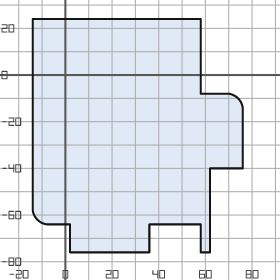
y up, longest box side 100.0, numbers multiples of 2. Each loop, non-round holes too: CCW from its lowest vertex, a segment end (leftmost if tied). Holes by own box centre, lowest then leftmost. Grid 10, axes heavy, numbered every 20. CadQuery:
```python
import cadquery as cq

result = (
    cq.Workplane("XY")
    .moveTo(2.0, -76.0)
    .lineTo(36.0, -76.0)
    .lineTo(36.0, -64.0)
    .lineTo(58.0, -64.0)
    .lineTo(58.0, -76.0)
    .lineTo(62.0, -76.0)
    .lineTo(62.0, -40.0)
    .lineTo(76.0, -40.0)
    .lineTo(76.0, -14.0)
    .threePointArc((74.0, -10.0), (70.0, -8.0))
    .lineTo(58.0, -8.0)
    .lineTo(58.0, 24.0)
    .lineTo(-14.0, 24.0)
    .lineTo(-14.0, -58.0)
    .threePointArc((-12.0, -62.0), (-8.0, -64.0))
    .lineTo(2.0, -64.0)
    .close()
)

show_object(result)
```